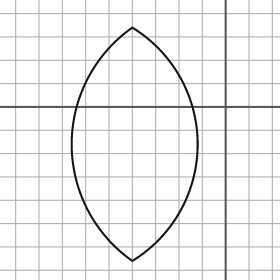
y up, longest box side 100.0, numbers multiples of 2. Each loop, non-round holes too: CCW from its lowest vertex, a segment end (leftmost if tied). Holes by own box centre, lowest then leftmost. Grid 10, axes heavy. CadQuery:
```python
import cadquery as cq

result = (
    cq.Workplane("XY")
    .moveTo(-40.0, -66.0)
    .threePointArc((-12.0, -16.0), (-40.0, 34.0))
    .threePointArc((-66.0, -16.0), (-40.0, -66.0))
    .close()
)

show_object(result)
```